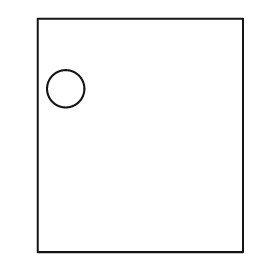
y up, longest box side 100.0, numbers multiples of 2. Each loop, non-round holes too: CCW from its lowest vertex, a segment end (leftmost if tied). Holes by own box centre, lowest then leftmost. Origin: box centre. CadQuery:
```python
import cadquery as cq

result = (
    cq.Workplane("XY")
    .moveTo(-44.0, -50.0)
    .lineTo(44.0, -50.0)
    .lineTo(44.0, 50.0)
    .lineTo(-44.0, 50.0)
    .close()
    .moveTo(-32.0, 20.0)
    .circle(8.0)
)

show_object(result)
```